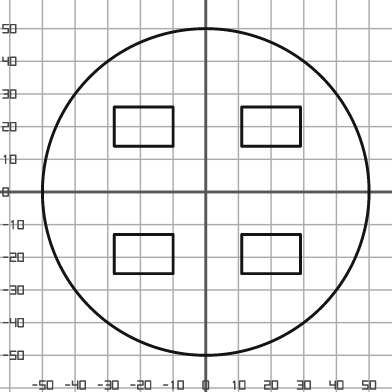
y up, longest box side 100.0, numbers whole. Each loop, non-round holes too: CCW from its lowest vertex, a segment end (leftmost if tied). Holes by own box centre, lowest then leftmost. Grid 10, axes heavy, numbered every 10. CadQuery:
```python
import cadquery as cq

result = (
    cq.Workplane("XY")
    .moveTo(0.0, 0.0)
    .circle(50.0)
    .moveTo(-28.0, -25.0)
    .lineTo(-10.0, -25.0)
    .lineTo(-10.0, -13.0)
    .lineTo(-28.0, -13.0)
    .close()
    .moveTo(11.0, -25.0)
    .lineTo(29.0, -25.0)
    .lineTo(29.0, -13.0)
    .lineTo(11.0, -13.0)
    .close()
    .moveTo(-28.0, 14.0)
    .lineTo(-10.0, 14.0)
    .lineTo(-10.0, 26.0)
    .lineTo(-28.0, 26.0)
    .close()
    .moveTo(11.0, 14.0)
    .lineTo(29.0, 14.0)
    .lineTo(29.0, 26.0)
    .lineTo(11.0, 26.0)
    .close()
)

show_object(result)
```